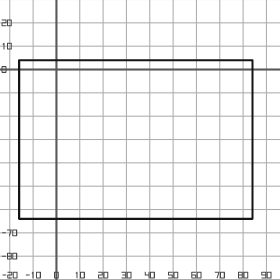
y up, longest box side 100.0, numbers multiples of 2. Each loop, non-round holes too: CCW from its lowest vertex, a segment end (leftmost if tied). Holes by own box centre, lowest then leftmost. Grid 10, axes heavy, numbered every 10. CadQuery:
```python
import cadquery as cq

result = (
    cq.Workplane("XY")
    .moveTo(-16.0, -64.0)
    .lineTo(84.0, -64.0)
    .lineTo(84.0, 4.0)
    .lineTo(-16.0, 4.0)
    .close()
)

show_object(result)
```